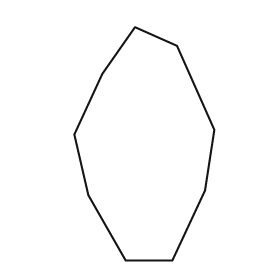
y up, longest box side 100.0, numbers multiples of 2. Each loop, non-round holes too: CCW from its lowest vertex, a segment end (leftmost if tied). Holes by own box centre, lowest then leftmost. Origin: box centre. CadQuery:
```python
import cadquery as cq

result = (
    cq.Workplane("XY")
    .moveTo(-8.0, -50.0)
    .lineTo(12.0, -50.0)
    .lineTo(26.0, -20.0)
    .lineTo(30.0, 6.0)
    .lineTo(14.0, 42.0)
    .lineTo(-4.0, 50.0)
    .lineTo(-18.0, 30.0)
    .lineTo(-30.0, 4.0)
    .lineTo(-24.0, -22.0)
    .close()
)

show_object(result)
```